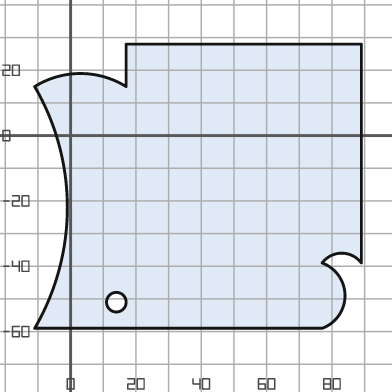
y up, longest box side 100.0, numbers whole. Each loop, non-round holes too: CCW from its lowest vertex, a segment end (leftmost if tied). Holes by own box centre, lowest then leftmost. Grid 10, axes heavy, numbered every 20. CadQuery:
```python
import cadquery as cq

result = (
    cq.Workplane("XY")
    .moveTo(-11.0, -59.0)
    .lineTo(77.0, -59.0)
    .threePointArc((84.0, -49.0), (77.0, -39.0))
    .threePointArc((83.0, -36.0), (89.0, -39.0))
    .lineTo(89.0, 28.0)
    .lineTo(17.0, 28.0)
    .lineTo(17.0, 15.0)
    .threePointArc((3.0, 19.0), (-11.0, 15.0))
    .threePointArc((-1.0, -22.0), (-11.0, -59.0))
    .close()
    .moveTo(14.0, -51.0)
    .circle(3.0)
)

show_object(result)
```